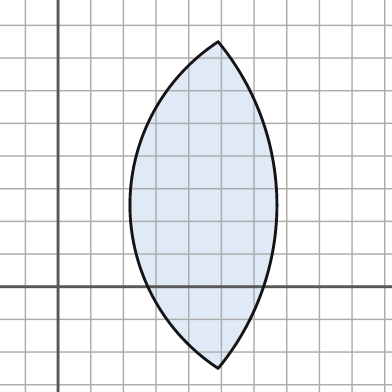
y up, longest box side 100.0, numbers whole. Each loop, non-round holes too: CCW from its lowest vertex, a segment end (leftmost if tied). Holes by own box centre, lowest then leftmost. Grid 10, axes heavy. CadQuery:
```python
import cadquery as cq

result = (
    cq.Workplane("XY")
    .moveTo(49.0, -25.0)
    .threePointArc((67.0, 25.0), (49.0, 75.0))
    .threePointArc((22.0, 25.0), (49.0, -25.0))
    .close()
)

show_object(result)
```